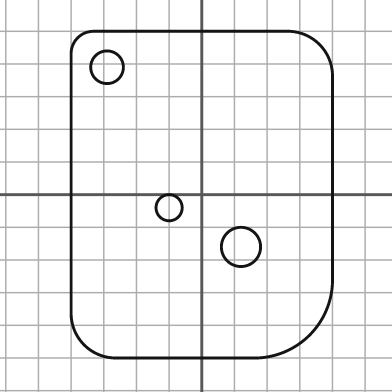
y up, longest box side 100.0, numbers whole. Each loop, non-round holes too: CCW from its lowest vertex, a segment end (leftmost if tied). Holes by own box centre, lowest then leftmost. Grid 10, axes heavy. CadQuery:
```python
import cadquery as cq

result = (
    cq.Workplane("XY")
    .moveTo(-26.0, -50.0)
    .lineTo(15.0, -50.0)
    .threePointArc((33.0, -43.0), (40.0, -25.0))
    .lineTo(40.0, 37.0)
    .threePointArc((36.0, 46.0), (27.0, 50.0))
    .lineTo(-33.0, 50.0)
    .threePointArc((-38.0, 48.0), (-40.0, 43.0))
    .lineTo(-40.0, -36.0)
    .threePointArc((-36.0, -46.0), (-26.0, -50.0))
    .close()
    .moveTo(12.0, -16.0)
    .circle(6.0)
    .moveTo(-10.0, -4.0)
    .circle(4.0)
    .moveTo(-29.0, 39.0)
    .circle(5.0)
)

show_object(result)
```